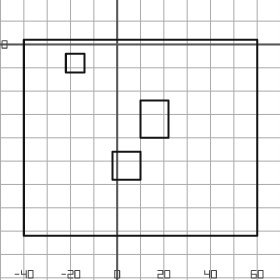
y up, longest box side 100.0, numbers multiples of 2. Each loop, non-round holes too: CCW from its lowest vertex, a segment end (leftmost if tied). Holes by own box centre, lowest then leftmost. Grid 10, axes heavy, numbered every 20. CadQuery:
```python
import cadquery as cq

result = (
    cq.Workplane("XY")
    .moveTo(-40.0, -82.0)
    .lineTo(60.0, -82.0)
    .lineTo(60.0, 2.0)
    .lineTo(-40.0, 2.0)
    .close()
    .moveTo(-2.0, -58.0)
    .lineTo(10.0, -58.0)
    .lineTo(10.0, -46.0)
    .lineTo(-2.0, -46.0)
    .close()
    .moveTo(10.0, -40.0)
    .lineTo(22.0, -40.0)
    .lineTo(22.0, -24.0)
    .lineTo(10.0, -24.0)
    .close()
    .moveTo(-22.0, -12.0)
    .lineTo(-14.0, -12.0)
    .lineTo(-14.0, -4.0)
    .lineTo(-22.0, -4.0)
    .close()
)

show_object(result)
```